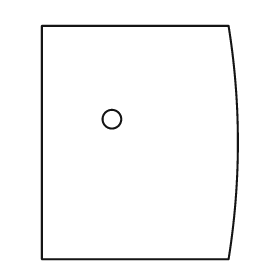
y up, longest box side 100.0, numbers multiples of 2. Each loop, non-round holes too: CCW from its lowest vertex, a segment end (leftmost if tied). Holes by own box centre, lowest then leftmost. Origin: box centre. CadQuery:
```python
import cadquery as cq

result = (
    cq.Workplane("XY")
    .moveTo(-42.0, -50.0)
    .lineTo(38.0, -50.0)
    .threePointArc((42.0, 0.0), (38.0, 50.0))
    .lineTo(-42.0, 50.0)
    .close()
    .moveTo(-12.0, 10.0)
    .circle(4.0)
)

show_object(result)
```